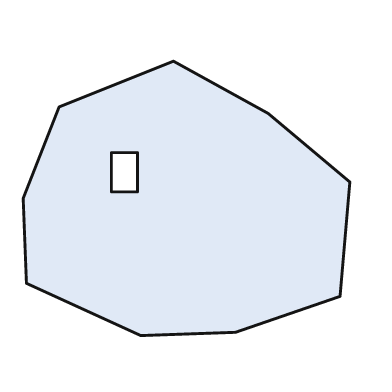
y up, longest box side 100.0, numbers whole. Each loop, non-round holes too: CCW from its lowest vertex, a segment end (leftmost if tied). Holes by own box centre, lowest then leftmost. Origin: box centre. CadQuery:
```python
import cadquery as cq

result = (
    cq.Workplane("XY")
    .moveTo(-14.0, -42.0)
    .lineTo(15.0, -41.0)
    .lineTo(47.0, -30.0)
    .lineTo(50.0, 5.0)
    .lineTo(25.0, 26.0)
    .lineTo(-4.0, 42.0)
    .lineTo(-39.0, 28.0)
    .lineTo(-50.0, 0.0)
    .lineTo(-49.0, -26.0)
    .close()
    .moveTo(-23.0, 2.0)
    .lineTo(-15.0, 2.0)
    .lineTo(-15.0, 14.0)
    .lineTo(-23.0, 14.0)
    .close()
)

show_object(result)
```